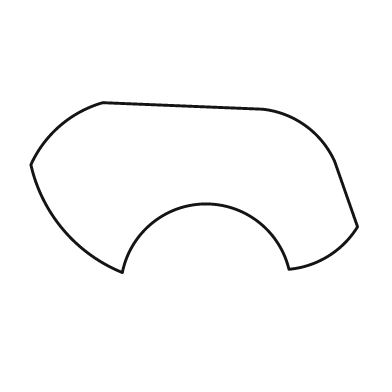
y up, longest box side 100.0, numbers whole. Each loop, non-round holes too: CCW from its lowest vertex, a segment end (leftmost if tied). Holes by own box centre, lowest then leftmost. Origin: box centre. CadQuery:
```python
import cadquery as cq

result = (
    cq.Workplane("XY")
    .moveTo(-22.0, -26.0)
    .threePointArc((3.0, -5.0), (29.0, -25.0))
    .threePointArc((41.0, -21.0), (50.0, -12.0))
    .lineTo(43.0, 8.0)
    .threePointArc((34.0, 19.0), (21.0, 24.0))
    .lineTo(-28.0, 26.0)
    .threePointArc((-41.0, 19.0), (-50.0, 7.0))
    .threePointArc((-40.0, -13.0), (-22.0, -26.0))
    .close()
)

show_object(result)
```